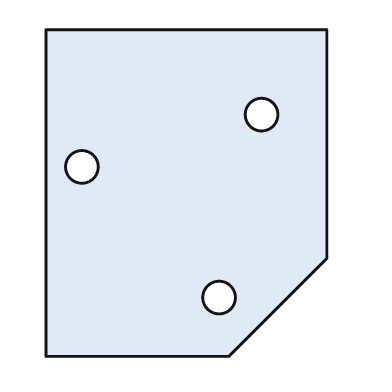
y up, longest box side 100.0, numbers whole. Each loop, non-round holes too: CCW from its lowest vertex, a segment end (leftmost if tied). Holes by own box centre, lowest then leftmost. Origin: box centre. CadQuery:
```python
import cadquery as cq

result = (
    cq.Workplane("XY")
    .moveTo(-43.0, -50.0)
    .lineTo(13.0, -50.0)
    .lineTo(43.0, -20.0)
    .lineTo(43.0, 50.0)
    .lineTo(-43.0, 50.0)
    .close()
    .moveTo(10.0, -32.0)
    .circle(5.0)
    .moveTo(-32.0, 8.0)
    .circle(5.0)
    .moveTo(23.0, 24.0)
    .circle(5.0)
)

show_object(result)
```